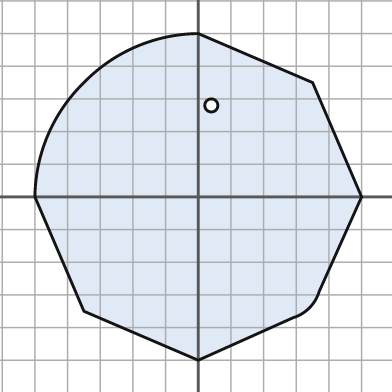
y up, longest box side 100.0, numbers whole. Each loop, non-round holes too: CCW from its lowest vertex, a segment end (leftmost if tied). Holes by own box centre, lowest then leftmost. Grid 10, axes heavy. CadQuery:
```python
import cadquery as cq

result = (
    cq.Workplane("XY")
    .moveTo(0.0, -50.0)
    .lineTo(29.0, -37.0)
    .threePointArc((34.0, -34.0), (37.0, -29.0))
    .lineTo(50.0, 0.0)
    .lineTo(35.0, 35.0)
    .lineTo(0.0, 50.0)
    .threePointArc((-19.0, 46.0), (-35.0, 35.0))
    .threePointArc((-46.0, 19.0), (-50.0, 0.0))
    .lineTo(-35.0, -35.0)
    .close()
    .moveTo(4.0, 28.0)
    .circle(2.0)
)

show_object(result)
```